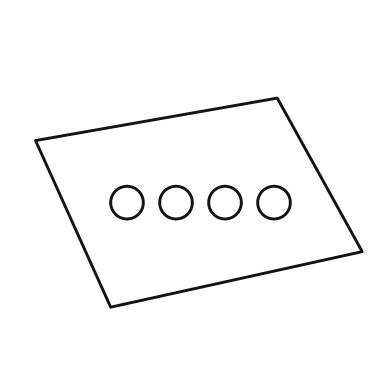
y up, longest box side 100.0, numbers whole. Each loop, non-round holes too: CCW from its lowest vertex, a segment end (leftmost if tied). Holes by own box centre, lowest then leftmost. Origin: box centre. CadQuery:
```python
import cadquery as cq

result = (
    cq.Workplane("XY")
    .moveTo(-27.0, -32.0)
    .lineTo(50.0, -15.0)
    .lineTo(24.0, 32.0)
    .lineTo(-50.0, 19.0)
    .close()
    .moveTo(-22.0, 0.0)
    .circle(5.0)
    .moveTo(-7.0, 0.0)
    .circle(5.0)
    .moveTo(8.0, 0.0)
    .circle(5.0)
    .moveTo(23.0, 0.0)
    .circle(5.0)
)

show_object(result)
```